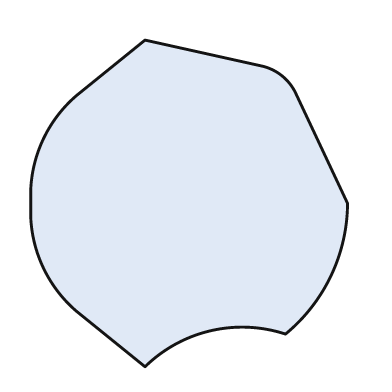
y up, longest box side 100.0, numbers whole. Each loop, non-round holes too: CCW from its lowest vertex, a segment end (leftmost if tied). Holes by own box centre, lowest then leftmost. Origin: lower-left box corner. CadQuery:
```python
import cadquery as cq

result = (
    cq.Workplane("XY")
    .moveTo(35.0, 0.0)
    .threePointArc((55.0, 11.0), (78.0, 10.0))
    .threePointArc((92.0, 28.0), (97.0, 50.0))
    .lineTo(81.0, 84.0)
    .threePointArc((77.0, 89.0), (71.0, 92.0))
    .lineTo(35.0, 100.0)
    .lineTo(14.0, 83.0)
    .threePointArc((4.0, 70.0), (0.0, 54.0))
    .lineTo(0.0, 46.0)
    .threePointArc((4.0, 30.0), (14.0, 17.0))
    .close()
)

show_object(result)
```